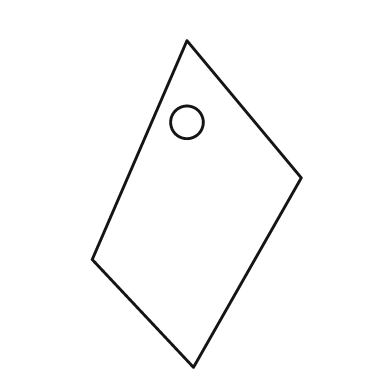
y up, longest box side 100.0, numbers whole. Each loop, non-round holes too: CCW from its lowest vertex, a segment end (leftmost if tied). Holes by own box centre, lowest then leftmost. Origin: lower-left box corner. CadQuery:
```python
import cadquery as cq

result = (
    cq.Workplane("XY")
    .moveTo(31.0, 0.0)
    .lineTo(64.0, 58.0)
    .lineTo(29.0, 100.0)
    .lineTo(0.0, 33.0)
    .close()
    .moveTo(29.0, 75.0)
    .circle(5.0)
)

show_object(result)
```